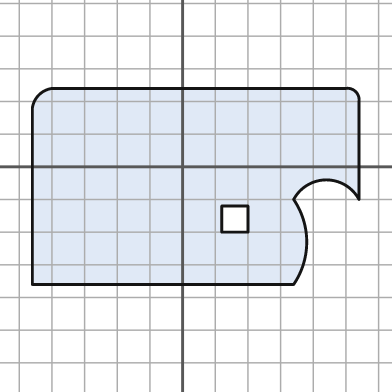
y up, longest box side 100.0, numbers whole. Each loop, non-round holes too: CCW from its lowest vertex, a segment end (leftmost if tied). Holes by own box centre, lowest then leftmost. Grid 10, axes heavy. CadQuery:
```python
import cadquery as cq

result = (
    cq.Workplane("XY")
    .moveTo(-46.0, -36.0)
    .lineTo(34.0, -36.0)
    .threePointArc((38.0, -23.0), (34.0, -10.0))
    .threePointArc((44.0, -4.0), (54.0, -10.0))
    .lineTo(54.0, 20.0)
    .threePointArc((53.0, 23.0), (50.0, 24.0))
    .lineTo(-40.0, 24.0)
    .threePointArc((-44.0, 22.0), (-46.0, 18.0))
    .close()
    .moveTo(12.0, -20.0)
    .lineTo(20.0, -20.0)
    .lineTo(20.0, -12.0)
    .lineTo(12.0, -12.0)
    .close()
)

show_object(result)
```